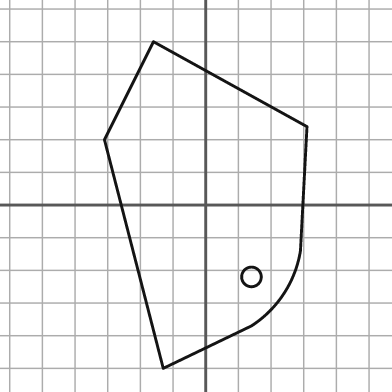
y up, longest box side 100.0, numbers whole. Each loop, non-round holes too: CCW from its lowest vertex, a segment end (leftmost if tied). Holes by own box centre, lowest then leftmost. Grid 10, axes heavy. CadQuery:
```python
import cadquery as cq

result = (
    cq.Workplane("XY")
    .moveTo(-13.0, -50.0)
    .lineTo(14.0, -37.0)
    .threePointArc((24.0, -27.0), (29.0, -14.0))
    .lineTo(31.0, 24.0)
    .lineTo(-16.0, 50.0)
    .lineTo(-31.0, 20.0)
    .close()
    .moveTo(14.0, -22.0)
    .circle(3.0)
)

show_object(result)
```